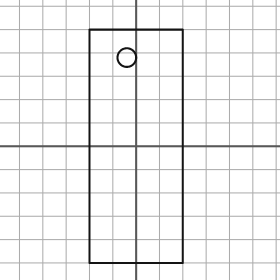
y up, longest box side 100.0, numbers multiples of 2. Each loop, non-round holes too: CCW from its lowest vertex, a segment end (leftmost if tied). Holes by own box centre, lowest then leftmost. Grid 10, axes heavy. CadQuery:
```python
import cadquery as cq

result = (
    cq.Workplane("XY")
    .moveTo(-20.0, -50.0)
    .lineTo(20.0, -50.0)
    .lineTo(20.0, 50.0)
    .lineTo(-20.0, 50.0)
    .close()
    .moveTo(-4.0, 38.0)
    .circle(4.0)
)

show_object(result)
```